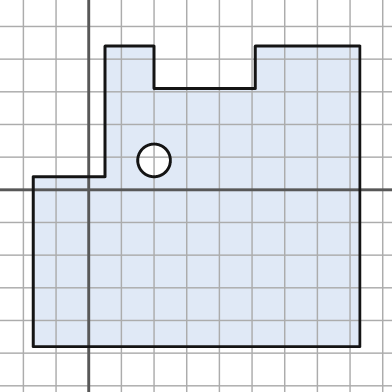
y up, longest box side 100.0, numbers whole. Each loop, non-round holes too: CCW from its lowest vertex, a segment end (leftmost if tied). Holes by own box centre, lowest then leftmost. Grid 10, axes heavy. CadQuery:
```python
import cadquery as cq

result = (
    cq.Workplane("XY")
    .moveTo(-17.0, -48.0)
    .lineTo(83.0, -48.0)
    .lineTo(83.0, 44.0)
    .lineTo(51.0, 44.0)
    .lineTo(51.0, 31.0)
    .lineTo(20.0, 31.0)
    .lineTo(20.0, 44.0)
    .lineTo(5.0, 44.0)
    .lineTo(5.0, 4.0)
    .lineTo(-17.0, 4.0)
    .close()
    .moveTo(20.0, 9.0)
    .circle(5.0)
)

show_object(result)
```